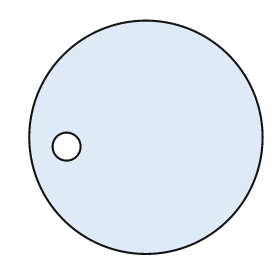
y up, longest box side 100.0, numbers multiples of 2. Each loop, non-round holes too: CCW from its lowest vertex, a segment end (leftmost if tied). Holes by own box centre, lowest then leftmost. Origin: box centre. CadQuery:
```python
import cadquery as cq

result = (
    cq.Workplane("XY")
    .moveTo(0.0, 0.0)
    .circle(50.0)
    .moveTo(-34.0, -4.0)
    .circle(6.0)
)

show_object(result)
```